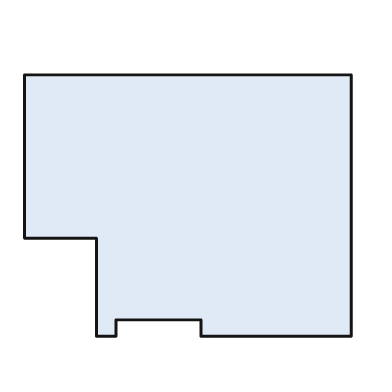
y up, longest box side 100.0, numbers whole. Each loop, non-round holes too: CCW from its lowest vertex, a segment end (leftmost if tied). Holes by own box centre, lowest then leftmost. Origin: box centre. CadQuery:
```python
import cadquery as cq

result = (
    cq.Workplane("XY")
    .moveTo(-28.0, -40.0)
    .lineTo(-22.0, -40.0)
    .lineTo(-22.0, -35.0)
    .lineTo(4.0, -35.0)
    .lineTo(4.0, -40.0)
    .lineTo(50.0, -40.0)
    .lineTo(50.0, 40.0)
    .lineTo(-50.0, 40.0)
    .lineTo(-50.0, -10.0)
    .lineTo(-28.0, -10.0)
    .close()
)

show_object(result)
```